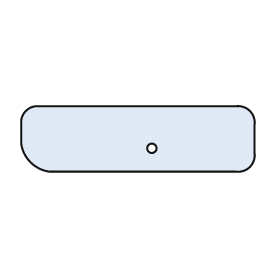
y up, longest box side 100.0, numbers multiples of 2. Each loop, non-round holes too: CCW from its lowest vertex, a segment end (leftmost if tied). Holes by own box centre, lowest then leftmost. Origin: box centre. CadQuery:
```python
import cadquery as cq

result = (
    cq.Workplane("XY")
    .moveTo(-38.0, -14.0)
    .lineTo(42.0, -14.0)
    .threePointArc((48.0, -12.0), (50.0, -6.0))
    .lineTo(50.0, 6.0)
    .threePointArc((48.0, 12.0), (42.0, 14.0))
    .lineTo(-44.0, 14.0)
    .threePointArc((-48.0, 12.0), (-50.0, 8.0))
    .lineTo(-50.0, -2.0)
    .threePointArc((-46.0, -10.0), (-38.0, -14.0))
    .close()
    .moveTo(6.0, -4.0)
    .circle(2.0)
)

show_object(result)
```